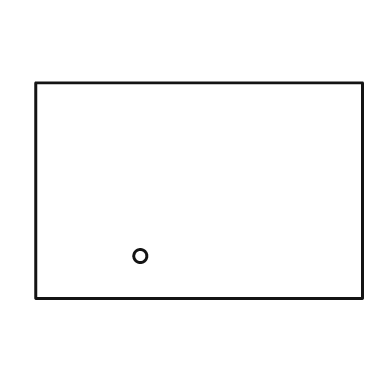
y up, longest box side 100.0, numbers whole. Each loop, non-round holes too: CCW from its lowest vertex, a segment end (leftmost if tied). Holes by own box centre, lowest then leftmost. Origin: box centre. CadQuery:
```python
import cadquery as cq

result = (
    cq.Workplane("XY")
    .moveTo(-50.0, -33.0)
    .lineTo(50.0, -33.0)
    .lineTo(50.0, 33.0)
    .lineTo(-50.0, 33.0)
    .close()
    .moveTo(-18.0, -20.0)
    .circle(2.0)
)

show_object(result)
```